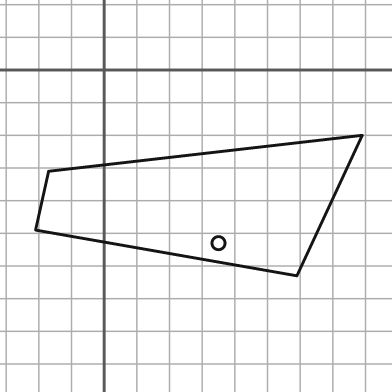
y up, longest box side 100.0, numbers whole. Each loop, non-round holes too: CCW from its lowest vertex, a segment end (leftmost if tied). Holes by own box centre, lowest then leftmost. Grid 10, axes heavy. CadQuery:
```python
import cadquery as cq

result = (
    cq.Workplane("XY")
    .moveTo(59.0, -63.0)
    .lineTo(79.0, -20.0)
    .lineTo(-17.0, -31.0)
    .lineTo(-21.0, -49.0)
    .close()
    .moveTo(35.0, -53.0)
    .circle(2.0)
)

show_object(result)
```